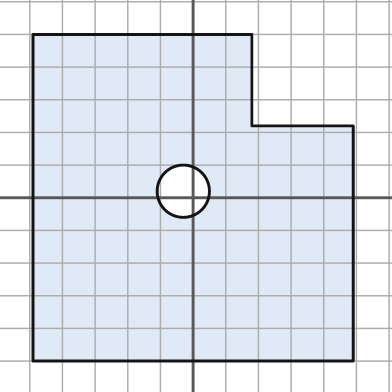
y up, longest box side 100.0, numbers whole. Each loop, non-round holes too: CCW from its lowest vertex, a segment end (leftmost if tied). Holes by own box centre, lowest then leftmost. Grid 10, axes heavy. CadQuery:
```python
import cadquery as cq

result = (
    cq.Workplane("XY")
    .moveTo(-49.0, -50.0)
    .lineTo(49.0, -50.0)
    .lineTo(49.0, 22.0)
    .lineTo(18.0, 22.0)
    .lineTo(18.0, 50.0)
    .lineTo(-49.0, 50.0)
    .close()
    .moveTo(-3.0, 2.0)
    .circle(8.0)
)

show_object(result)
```